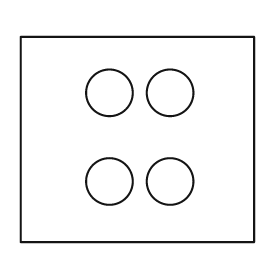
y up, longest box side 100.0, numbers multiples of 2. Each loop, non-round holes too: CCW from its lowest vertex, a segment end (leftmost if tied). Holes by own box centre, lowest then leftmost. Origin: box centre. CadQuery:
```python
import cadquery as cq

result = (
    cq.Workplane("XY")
    .moveTo(-50.0, -44.0)
    .lineTo(50.0, -44.0)
    .lineTo(50.0, 44.0)
    .lineTo(-50.0, 44.0)
    .close()
    .moveTo(-12.0, -18.0)
    .circle(10.0)
    .moveTo(14.0, -18.0)
    .circle(10.0)
    .moveTo(-12.0, 20.0)
    .circle(10.0)
    .moveTo(14.0, 20.0)
    .circle(10.0)
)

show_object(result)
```